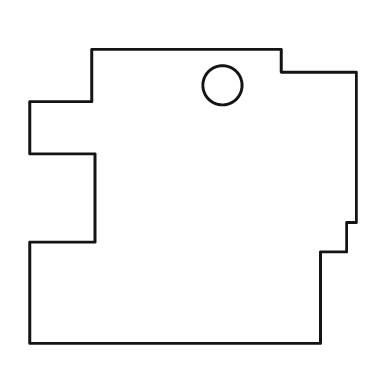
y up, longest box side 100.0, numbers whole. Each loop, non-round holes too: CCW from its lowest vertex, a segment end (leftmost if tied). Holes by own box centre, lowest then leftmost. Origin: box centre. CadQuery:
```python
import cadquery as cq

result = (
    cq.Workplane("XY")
    .moveTo(-50.0, -45.0)
    .lineTo(39.0, -45.0)
    .lineTo(39.0, -17.0)
    .lineTo(47.0, -17.0)
    .lineTo(47.0, -8.0)
    .lineTo(50.0, -8.0)
    .lineTo(50.0, 38.0)
    .lineTo(27.0, 38.0)
    .lineTo(27.0, 45.0)
    .lineTo(-31.0, 45.0)
    .lineTo(-31.0, 29.0)
    .lineTo(-50.0, 29.0)
    .lineTo(-50.0, 13.0)
    .lineTo(-30.0, 13.0)
    .lineTo(-30.0, -14.0)
    .lineTo(-50.0, -14.0)
    .close()
    .moveTo(9.0, 34.0)
    .circle(6.0)
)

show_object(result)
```